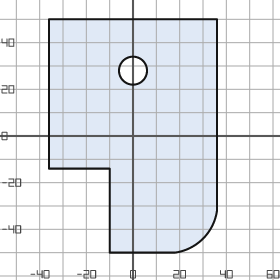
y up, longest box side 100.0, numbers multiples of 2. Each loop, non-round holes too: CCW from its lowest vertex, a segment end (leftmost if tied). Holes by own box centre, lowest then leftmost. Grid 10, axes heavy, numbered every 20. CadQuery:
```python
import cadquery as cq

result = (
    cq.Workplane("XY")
    .moveTo(-10.0, -50.0)
    .lineTo(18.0, -50.0)
    .threePointArc((30.0, -44.0), (36.0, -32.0))
    .lineTo(36.0, 50.0)
    .lineTo(-36.0, 50.0)
    .lineTo(-36.0, -14.0)
    .lineTo(-10.0, -14.0)
    .close()
    .moveTo(0.0, 28.0)
    .circle(6.0)
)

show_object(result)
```